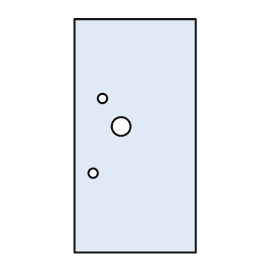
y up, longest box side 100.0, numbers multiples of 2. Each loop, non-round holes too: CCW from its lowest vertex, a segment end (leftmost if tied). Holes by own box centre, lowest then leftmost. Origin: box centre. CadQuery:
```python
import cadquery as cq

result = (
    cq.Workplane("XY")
    .moveTo(-26.0, -50.0)
    .lineTo(26.0, -50.0)
    .lineTo(26.0, 50.0)
    .lineTo(-26.0, 50.0)
    .close()
    .moveTo(-18.0, -16.0)
    .circle(2.0)
    .moveTo(-6.0, 4.0)
    .circle(4.0)
    .moveTo(-14.0, 16.0)
    .circle(2.0)
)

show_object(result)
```